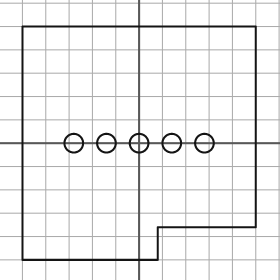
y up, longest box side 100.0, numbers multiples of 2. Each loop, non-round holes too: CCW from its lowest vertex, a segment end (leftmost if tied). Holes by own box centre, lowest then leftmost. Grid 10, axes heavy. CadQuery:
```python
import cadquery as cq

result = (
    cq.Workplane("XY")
    .moveTo(-50.0, -50.0)
    .lineTo(8.0, -50.0)
    .lineTo(8.0, -36.0)
    .lineTo(50.0, -36.0)
    .lineTo(50.0, 50.0)
    .lineTo(-50.0, 50.0)
    .close()
    .moveTo(-28.0, 0.0)
    .circle(4.0)
    .moveTo(-14.0, 0.0)
    .circle(4.0)
    .moveTo(0.0, 0.0)
    .circle(4.0)
    .moveTo(14.0, 0.0)
    .circle(4.0)
    .moveTo(28.0, 0.0)
    .circle(4.0)
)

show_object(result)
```